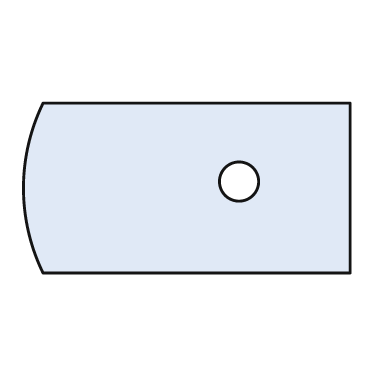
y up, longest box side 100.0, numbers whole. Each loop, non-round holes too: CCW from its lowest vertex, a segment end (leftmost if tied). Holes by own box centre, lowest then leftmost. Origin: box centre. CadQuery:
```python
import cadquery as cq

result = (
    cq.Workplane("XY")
    .moveTo(-44.0, -26.0)
    .lineTo(50.0, -26.0)
    .lineTo(50.0, 26.0)
    .lineTo(-44.0, 26.0)
    .threePointArc((-50.0, 0.0), (-44.0, -26.0))
    .close()
    .moveTo(16.0, 2.0)
    .circle(6.0)
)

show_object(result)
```